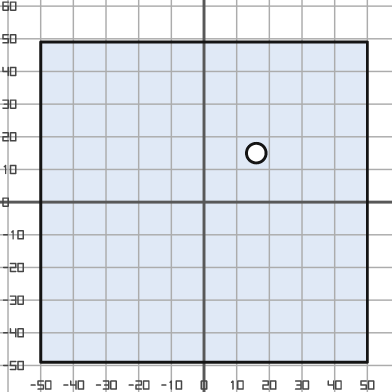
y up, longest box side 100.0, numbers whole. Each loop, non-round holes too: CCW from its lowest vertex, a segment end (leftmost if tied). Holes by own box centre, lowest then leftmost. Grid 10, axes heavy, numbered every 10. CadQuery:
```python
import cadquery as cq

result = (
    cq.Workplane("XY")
    .moveTo(-50.0, -49.0)
    .lineTo(50.0, -49.0)
    .lineTo(50.0, 49.0)
    .lineTo(-50.0, 49.0)
    .close()
    .moveTo(16.0, 15.0)
    .circle(3.0)
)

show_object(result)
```